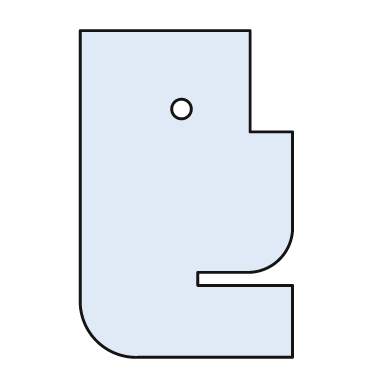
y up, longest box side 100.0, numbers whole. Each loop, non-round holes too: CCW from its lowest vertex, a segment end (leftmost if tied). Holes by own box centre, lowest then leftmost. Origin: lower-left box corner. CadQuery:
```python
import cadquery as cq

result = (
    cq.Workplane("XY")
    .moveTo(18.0, 0.0)
    .lineTo(65.0, 0.0)
    .lineTo(65.0, 22.0)
    .lineTo(36.0, 22.0)
    .lineTo(36.0, 26.0)
    .lineTo(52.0, 26.0)
    .threePointArc((61.0, 30.0), (65.0, 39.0))
    .lineTo(65.0, 69.0)
    .lineTo(52.0, 69.0)
    .lineTo(52.0, 100.0)
    .lineTo(0.0, 100.0)
    .lineTo(0.0, 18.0)
    .threePointArc((5.0, 5.0), (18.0, 0.0))
    .close()
    .moveTo(31.0, 76.0)
    .circle(3.0)
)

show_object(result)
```